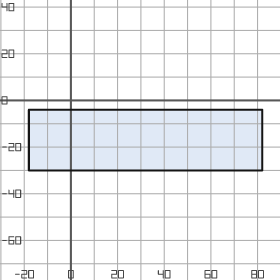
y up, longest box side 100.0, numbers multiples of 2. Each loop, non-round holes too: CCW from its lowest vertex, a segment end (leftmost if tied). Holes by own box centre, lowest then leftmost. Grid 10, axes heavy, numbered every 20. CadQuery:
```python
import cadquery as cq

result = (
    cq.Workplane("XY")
    .moveTo(-18.0, -30.0)
    .lineTo(82.0, -30.0)
    .lineTo(82.0, -4.0)
    .lineTo(-18.0, -4.0)
    .close()
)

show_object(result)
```